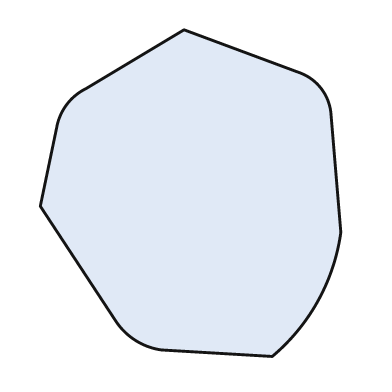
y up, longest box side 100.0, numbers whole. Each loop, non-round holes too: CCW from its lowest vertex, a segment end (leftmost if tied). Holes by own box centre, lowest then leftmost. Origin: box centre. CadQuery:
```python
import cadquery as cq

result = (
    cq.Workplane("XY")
    .moveTo(25.0, -50.0)
    .threePointArc((39.0, -33.0), (46.0, -12.0))
    .lineTo(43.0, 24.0)
    .threePointArc((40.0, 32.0), (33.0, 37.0))
    .lineTo(-2.0, 50.0)
    .lineTo(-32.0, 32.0)
    .threePointArc((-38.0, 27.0), (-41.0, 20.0))
    .lineTo(-46.0, -4.0)
    .lineTo(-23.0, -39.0)
    .threePointArc((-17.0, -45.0), (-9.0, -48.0))
    .close()
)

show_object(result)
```